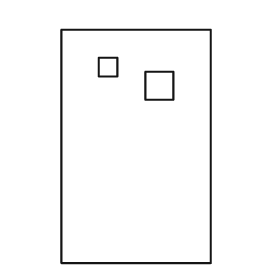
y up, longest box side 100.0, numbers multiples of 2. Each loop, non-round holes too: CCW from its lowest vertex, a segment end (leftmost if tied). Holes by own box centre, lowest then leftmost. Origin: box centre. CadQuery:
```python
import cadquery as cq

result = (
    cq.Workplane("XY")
    .moveTo(-32.0, -50.0)
    .lineTo(32.0, -50.0)
    .lineTo(32.0, 50.0)
    .lineTo(-32.0, 50.0)
    .close()
    .moveTo(4.0, 20.0)
    .lineTo(16.0, 20.0)
    .lineTo(16.0, 32.0)
    .lineTo(4.0, 32.0)
    .close()
    .moveTo(-16.0, 30.0)
    .lineTo(-8.0, 30.0)
    .lineTo(-8.0, 38.0)
    .lineTo(-16.0, 38.0)
    .close()
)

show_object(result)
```